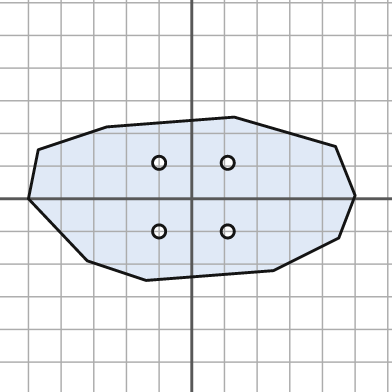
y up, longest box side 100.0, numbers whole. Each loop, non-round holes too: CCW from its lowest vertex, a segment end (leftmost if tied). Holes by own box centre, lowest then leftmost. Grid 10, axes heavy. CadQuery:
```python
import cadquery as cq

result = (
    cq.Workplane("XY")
    .moveTo(-14.0, -25.0)
    .lineTo(25.0, -22.0)
    .lineTo(45.0, -12.0)
    .lineTo(50.0, 1.0)
    .lineTo(44.0, 16.0)
    .lineTo(13.0, 25.0)
    .lineTo(-26.0, 22.0)
    .lineTo(-47.0, 15.0)
    .lineTo(-50.0, 0.0)
    .lineTo(-32.0, -19.0)
    .close()
    .moveTo(-10.0, -10.0)
    .circle(2.0)
    .moveTo(11.0, -10.0)
    .circle(2.0)
    .moveTo(-10.0, 11.0)
    .circle(2.0)
    .moveTo(11.0, 11.0)
    .circle(2.0)
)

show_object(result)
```